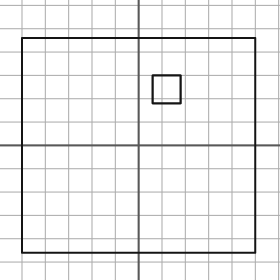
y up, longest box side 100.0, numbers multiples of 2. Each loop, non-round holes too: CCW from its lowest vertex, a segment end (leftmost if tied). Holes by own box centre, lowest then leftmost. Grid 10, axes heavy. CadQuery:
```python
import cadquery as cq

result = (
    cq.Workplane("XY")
    .moveTo(-50.0, -46.0)
    .lineTo(50.0, -46.0)
    .lineTo(50.0, 46.0)
    .lineTo(-50.0, 46.0)
    .close()
    .moveTo(6.0, 18.0)
    .lineTo(18.0, 18.0)
    .lineTo(18.0, 30.0)
    .lineTo(6.0, 30.0)
    .close()
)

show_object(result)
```